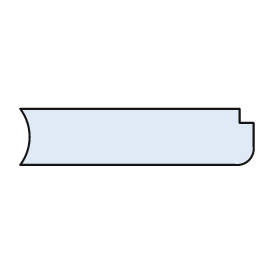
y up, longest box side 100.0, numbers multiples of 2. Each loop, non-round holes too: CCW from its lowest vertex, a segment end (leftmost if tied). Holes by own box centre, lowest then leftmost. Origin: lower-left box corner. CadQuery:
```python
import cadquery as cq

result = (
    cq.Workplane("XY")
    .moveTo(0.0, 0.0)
    .lineTo(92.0, 0.0)
    .threePointArc((98.0, 2.0), (100.0, 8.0))
    .lineTo(100.0, 18.0)
    .lineTo(94.0, 18.0)
    .lineTo(94.0, 24.0)
    .lineTo(0.0, 24.0)
    .threePointArc((4.0, 12.0), (0.0, 0.0))
    .close()
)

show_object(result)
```